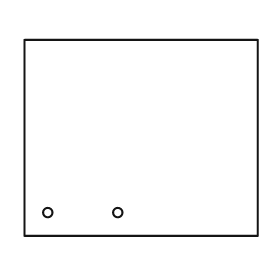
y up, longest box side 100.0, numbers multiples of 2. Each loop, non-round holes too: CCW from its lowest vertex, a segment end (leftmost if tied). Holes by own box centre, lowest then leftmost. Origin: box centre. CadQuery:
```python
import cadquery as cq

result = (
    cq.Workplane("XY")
    .moveTo(-50.0, -42.0)
    .lineTo(50.0, -42.0)
    .lineTo(50.0, 42.0)
    .lineTo(-50.0, 42.0)
    .close()
    .moveTo(-40.0, -32.0)
    .circle(2.0)
    .moveTo(-10.0, -32.0)
    .circle(2.0)
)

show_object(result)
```